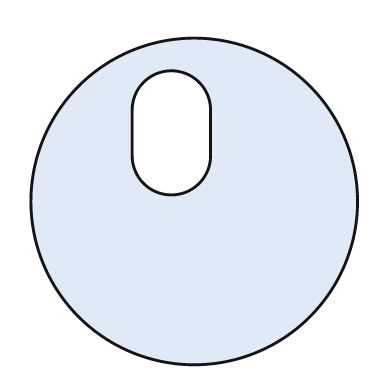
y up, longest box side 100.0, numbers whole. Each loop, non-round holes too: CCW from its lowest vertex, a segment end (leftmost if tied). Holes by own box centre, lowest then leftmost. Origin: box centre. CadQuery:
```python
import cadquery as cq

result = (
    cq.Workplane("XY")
    .moveTo(0.0, 0.0)
    .circle(50.0)
    .moveTo(-19.0, 14.0)
    .threePointArc((-7.0, 2.0), (5.0, 14.0))
    .lineTo(5.0, 28.0)
    .threePointArc((-7.0, 40.0), (-19.0, 28.0))
    .close()
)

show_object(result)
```